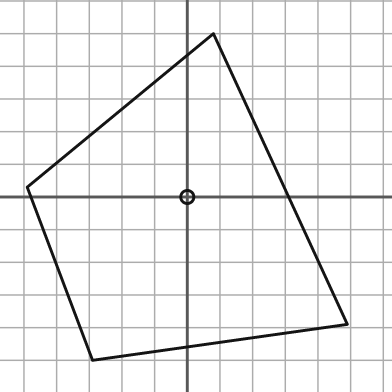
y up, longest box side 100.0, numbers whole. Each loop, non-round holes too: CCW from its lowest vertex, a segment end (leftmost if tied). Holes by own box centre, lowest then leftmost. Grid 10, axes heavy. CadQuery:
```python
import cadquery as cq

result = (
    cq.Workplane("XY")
    .moveTo(-29.0, -50.0)
    .lineTo(49.0, -39.0)
    .lineTo(8.0, 50.0)
    .lineTo(-49.0, 3.0)
    .close()
    .moveTo(0.0, 0.0)
    .circle(2.0)
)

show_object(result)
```